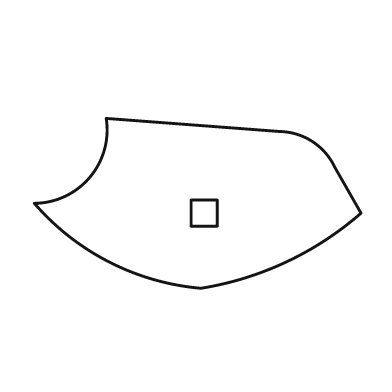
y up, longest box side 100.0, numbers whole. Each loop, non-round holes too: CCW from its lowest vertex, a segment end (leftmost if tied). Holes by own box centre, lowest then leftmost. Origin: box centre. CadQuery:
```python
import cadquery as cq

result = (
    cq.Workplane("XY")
    .moveTo(1.0, -26.0)
    .threePointArc((27.0, -18.0), (50.0, -3.0))
    .lineTo(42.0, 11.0)
    .threePointArc((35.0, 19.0), (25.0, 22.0))
    .lineTo(-28.0, 26.0)
    .threePointArc((-33.0, 8.0), (-50.0, 0.0))
    .threePointArc((-27.0, -18.0), (1.0, -26.0))
    .close()
    .moveTo(-2.0, -7.0)
    .lineTo(6.0, -7.0)
    .lineTo(6.0, 1.0)
    .lineTo(-2.0, 1.0)
    .close()
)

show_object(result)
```